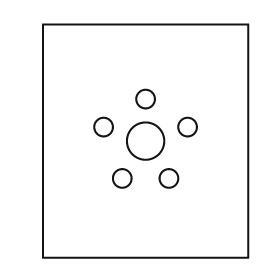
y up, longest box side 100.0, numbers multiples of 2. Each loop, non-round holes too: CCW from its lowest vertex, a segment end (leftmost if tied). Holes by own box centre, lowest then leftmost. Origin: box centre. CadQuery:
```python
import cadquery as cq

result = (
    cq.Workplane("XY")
    .moveTo(-44.0, -50.0)
    .lineTo(44.0, -50.0)
    .lineTo(44.0, 50.0)
    .lineTo(-44.0, 50.0)
    .close()
    .moveTo(-10.0, -16.0)
    .circle(4.0)
    .moveTo(10.0, -16.0)
    .circle(4.0)
    .moveTo(0.0, 0.0)
    .circle(8.0)
    .moveTo(-18.0, 6.0)
    .circle(4.0)
    .moveTo(18.0, 6.0)
    .circle(4.0)
    .moveTo(0.0, 18.0)
    .circle(4.0)
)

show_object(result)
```